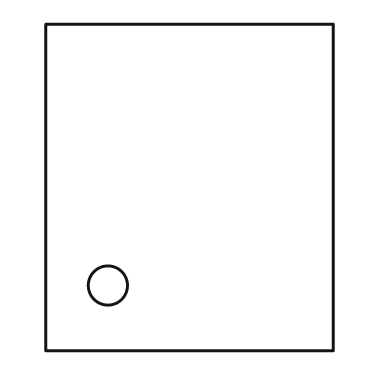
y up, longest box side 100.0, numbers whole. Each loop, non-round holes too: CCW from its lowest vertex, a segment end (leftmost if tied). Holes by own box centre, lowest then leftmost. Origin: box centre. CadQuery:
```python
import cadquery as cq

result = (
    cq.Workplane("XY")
    .moveTo(-44.0, -50.0)
    .lineTo(44.0, -50.0)
    .lineTo(44.0, 50.0)
    .lineTo(-44.0, 50.0)
    .close()
    .moveTo(-25.0, -30.0)
    .circle(6.0)
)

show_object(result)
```